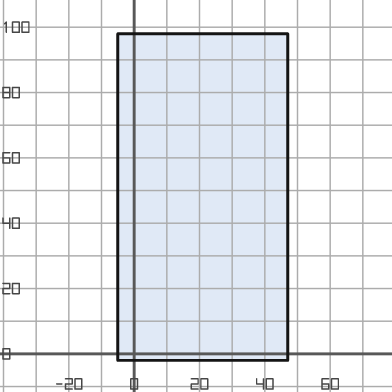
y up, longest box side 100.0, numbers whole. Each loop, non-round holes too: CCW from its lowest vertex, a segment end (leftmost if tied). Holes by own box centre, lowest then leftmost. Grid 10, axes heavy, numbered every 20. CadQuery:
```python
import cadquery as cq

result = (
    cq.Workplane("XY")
    .moveTo(-5.0, -2.0)
    .lineTo(47.0, -2.0)
    .lineTo(47.0, 98.0)
    .lineTo(-5.0, 98.0)
    .close()
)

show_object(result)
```